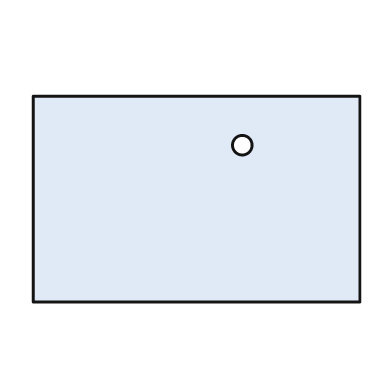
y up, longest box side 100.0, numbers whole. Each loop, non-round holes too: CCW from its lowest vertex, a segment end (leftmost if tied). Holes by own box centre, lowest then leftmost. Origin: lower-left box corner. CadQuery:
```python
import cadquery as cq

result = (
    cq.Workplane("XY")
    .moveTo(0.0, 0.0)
    .lineTo(100.0, 0.0)
    .lineTo(100.0, 63.0)
    .lineTo(0.0, 63.0)
    .close()
    .moveTo(64.0, 48.0)
    .circle(3.0)
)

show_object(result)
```